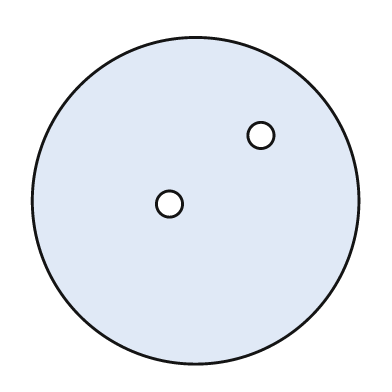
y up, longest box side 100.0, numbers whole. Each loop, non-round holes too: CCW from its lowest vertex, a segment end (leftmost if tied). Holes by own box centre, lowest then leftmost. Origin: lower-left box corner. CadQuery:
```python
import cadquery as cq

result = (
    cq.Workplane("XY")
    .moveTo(50.0, 50.0)
    .circle(50.0)
    .moveTo(42.0, 49.0)
    .circle(4.0)
    .moveTo(70.0, 70.0)
    .circle(4.0)
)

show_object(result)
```